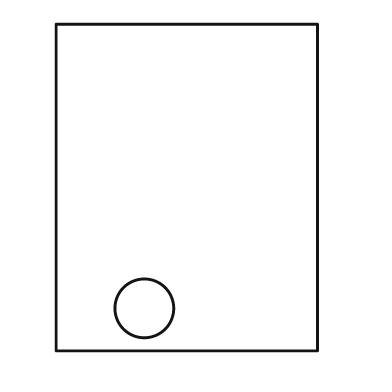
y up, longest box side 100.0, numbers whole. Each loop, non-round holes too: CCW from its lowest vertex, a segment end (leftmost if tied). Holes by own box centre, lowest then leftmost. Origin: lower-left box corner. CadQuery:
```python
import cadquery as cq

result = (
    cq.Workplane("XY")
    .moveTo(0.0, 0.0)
    .lineTo(80.0, 0.0)
    .lineTo(80.0, 100.0)
    .lineTo(0.0, 100.0)
    .close()
    .moveTo(27.0, 13.0)
    .circle(9.0)
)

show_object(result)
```